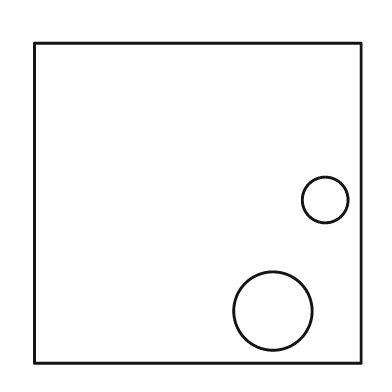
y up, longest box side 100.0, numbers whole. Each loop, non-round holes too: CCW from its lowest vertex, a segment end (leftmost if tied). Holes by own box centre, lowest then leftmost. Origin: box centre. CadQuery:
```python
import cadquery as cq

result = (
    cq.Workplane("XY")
    .moveTo(-50.0, -49.0)
    .lineTo(50.0, -49.0)
    .lineTo(50.0, 49.0)
    .lineTo(-50.0, 49.0)
    .close()
    .moveTo(23.0, -33.0)
    .circle(12.0)
    .moveTo(39.0, 1.0)
    .circle(7.0)
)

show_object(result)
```